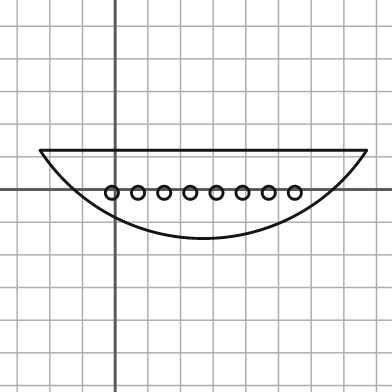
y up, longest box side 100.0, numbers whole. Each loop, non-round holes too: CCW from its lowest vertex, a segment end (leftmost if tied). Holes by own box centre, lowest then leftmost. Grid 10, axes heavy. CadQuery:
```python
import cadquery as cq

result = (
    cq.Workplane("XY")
    .moveTo(-23.0, 12.0)
    .threePointArc((27.0, -15.0), (77.0, 12.0))
    .close()
    .moveTo(-1.0, -1.0)
    .circle(2.0)
    .moveTo(7.0, -1.0)
    .circle(2.0)
    .moveTo(15.0, -1.0)
    .circle(2.0)
    .moveTo(23.0, -1.0)
    .circle(2.0)
    .moveTo(31.0, -1.0)
    .circle(2.0)
    .moveTo(39.0, -1.0)
    .circle(2.0)
    .moveTo(47.0, -1.0)
    .circle(2.0)
    .moveTo(55.0, -1.0)
    .circle(2.0)
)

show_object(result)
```